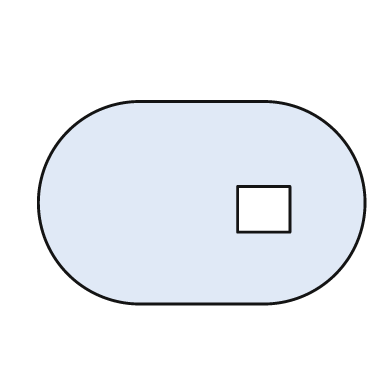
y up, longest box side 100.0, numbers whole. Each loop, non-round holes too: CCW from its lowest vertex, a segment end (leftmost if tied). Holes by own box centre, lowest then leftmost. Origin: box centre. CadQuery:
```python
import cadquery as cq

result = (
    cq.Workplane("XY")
    .moveTo(-19.0, -31.0)
    .lineTo(19.0, -31.0)
    .threePointArc((50.0, 0.0), (19.0, 31.0))
    .lineTo(-19.0, 31.0)
    .threePointArc((-50.0, 0.0), (-19.0, -31.0))
    .close()
    .moveTo(11.0, -9.0)
    .lineTo(27.0, -9.0)
    .lineTo(27.0, 5.0)
    .lineTo(11.0, 5.0)
    .close()
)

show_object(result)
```